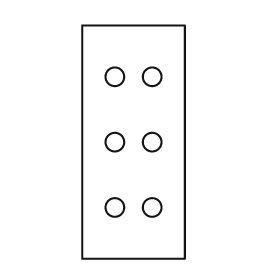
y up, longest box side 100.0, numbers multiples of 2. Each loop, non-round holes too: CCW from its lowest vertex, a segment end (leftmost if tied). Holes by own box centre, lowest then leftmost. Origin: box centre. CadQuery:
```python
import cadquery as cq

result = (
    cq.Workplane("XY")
    .moveTo(-22.0, -50.0)
    .lineTo(22.0, -50.0)
    .lineTo(22.0, 50.0)
    .lineTo(-22.0, 50.0)
    .close()
    .moveTo(-8.0, -28.0)
    .circle(4.0)
    .moveTo(8.0, -28.0)
    .circle(4.0)
    .moveTo(-8.0, 0.0)
    .circle(4.0)
    .moveTo(8.0, 0.0)
    .circle(4.0)
    .moveTo(-8.0, 28.0)
    .circle(4.0)
    .moveTo(8.0, 28.0)
    .circle(4.0)
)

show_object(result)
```